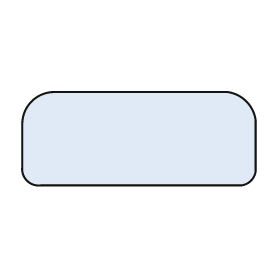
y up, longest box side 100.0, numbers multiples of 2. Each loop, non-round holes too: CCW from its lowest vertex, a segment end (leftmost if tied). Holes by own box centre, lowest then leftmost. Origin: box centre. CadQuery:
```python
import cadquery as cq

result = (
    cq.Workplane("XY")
    .moveTo(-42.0, -20.0)
    .lineTo(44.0, -20.0)
    .threePointArc((48.0, -18.0), (50.0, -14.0))
    .lineTo(50.0, 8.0)
    .threePointArc((46.0, 16.0), (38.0, 20.0))
    .lineTo(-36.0, 20.0)
    .threePointArc((-46.0, 16.0), (-50.0, 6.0))
    .lineTo(-50.0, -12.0)
    .threePointArc((-48.0, -18.0), (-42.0, -20.0))
    .close()
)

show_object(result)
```